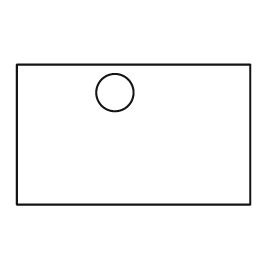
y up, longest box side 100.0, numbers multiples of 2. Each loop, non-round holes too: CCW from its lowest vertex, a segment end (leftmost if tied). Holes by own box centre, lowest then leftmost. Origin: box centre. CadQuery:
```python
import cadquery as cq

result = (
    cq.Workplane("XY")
    .moveTo(-50.0, -30.0)
    .lineTo(50.0, -30.0)
    .lineTo(50.0, 30.0)
    .lineTo(-50.0, 30.0)
    .close()
    .moveTo(-8.0, 18.0)
    .circle(8.0)
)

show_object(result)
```